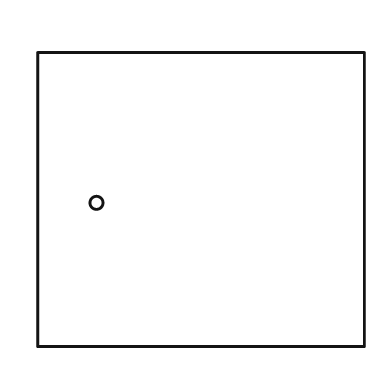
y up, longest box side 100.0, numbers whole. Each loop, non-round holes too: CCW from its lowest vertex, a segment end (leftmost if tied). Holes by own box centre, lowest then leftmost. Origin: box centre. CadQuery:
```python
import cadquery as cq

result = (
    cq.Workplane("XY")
    .moveTo(-50.0, -45.0)
    .lineTo(50.0, -45.0)
    .lineTo(50.0, 45.0)
    .lineTo(-50.0, 45.0)
    .close()
    .moveTo(-32.0, -1.0)
    .circle(2.0)
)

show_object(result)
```